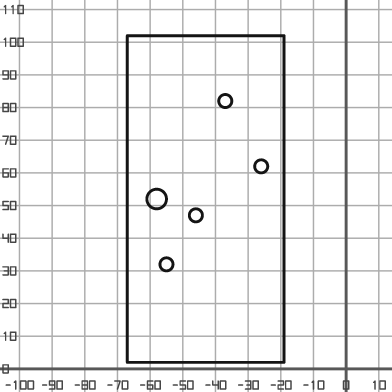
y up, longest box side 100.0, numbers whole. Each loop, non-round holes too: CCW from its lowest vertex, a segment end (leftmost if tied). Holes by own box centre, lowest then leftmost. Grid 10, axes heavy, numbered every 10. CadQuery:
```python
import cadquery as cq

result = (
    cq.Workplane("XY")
    .moveTo(-67.0, 2.0)
    .lineTo(-19.0, 2.0)
    .lineTo(-19.0, 102.0)
    .lineTo(-67.0, 102.0)
    .close()
    .moveTo(-55.0, 32.0)
    .circle(2.0)
    .moveTo(-46.0, 47.0)
    .circle(2.0)
    .moveTo(-58.0, 52.0)
    .circle(3.0)
    .moveTo(-26.0, 62.0)
    .circle(2.0)
    .moveTo(-37.0, 82.0)
    .circle(2.0)
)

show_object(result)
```